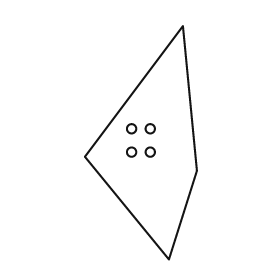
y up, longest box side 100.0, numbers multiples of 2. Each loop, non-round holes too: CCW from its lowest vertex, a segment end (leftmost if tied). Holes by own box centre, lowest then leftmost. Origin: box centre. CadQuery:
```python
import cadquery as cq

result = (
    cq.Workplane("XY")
    .moveTo(12.0, -50.0)
    .lineTo(24.0, -12.0)
    .lineTo(18.0, 50.0)
    .lineTo(-24.0, -6.0)
    .close()
    .moveTo(-4.0, -4.0)
    .circle(2.0)
    .moveTo(4.0, -4.0)
    .circle(2.0)
    .moveTo(-4.0, 6.0)
    .circle(2.0)
    .moveTo(4.0, 6.0)
    .circle(2.0)
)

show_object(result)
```